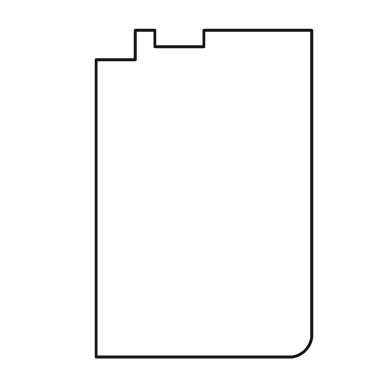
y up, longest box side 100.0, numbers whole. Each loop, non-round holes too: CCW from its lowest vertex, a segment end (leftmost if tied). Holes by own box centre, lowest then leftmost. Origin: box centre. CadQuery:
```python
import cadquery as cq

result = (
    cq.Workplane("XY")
    .moveTo(-33.0, -50.0)
    .lineTo(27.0, -50.0)
    .threePointArc((31.0, -48.0), (33.0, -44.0))
    .lineTo(33.0, 50.0)
    .lineTo(0.0, 50.0)
    .lineTo(0.0, 45.0)
    .lineTo(-15.0, 45.0)
    .lineTo(-15.0, 50.0)
    .lineTo(-21.0, 50.0)
    .lineTo(-21.0, 41.0)
    .lineTo(-33.0, 41.0)
    .close()
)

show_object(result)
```